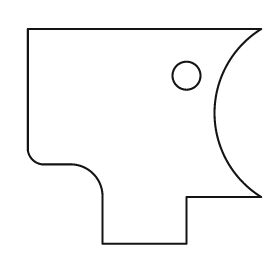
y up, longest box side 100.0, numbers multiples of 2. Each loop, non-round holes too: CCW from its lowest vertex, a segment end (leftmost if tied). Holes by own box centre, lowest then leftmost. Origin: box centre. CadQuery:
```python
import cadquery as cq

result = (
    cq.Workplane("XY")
    .moveTo(-18.0, -46.0)
    .lineTo(18.0, -46.0)
    .lineTo(18.0, -26.0)
    .lineTo(50.0, -26.0)
    .threePointArc((30.0, 10.0), (50.0, 46.0))
    .lineTo(-50.0, 46.0)
    .lineTo(-50.0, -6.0)
    .threePointArc((-48.0, -10.0), (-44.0, -12.0))
    .lineTo(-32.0, -12.0)
    .threePointArc((-22.0, -16.0), (-18.0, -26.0))
    .close()
    .moveTo(18.0, 26.0)
    .circle(6.0)
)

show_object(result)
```